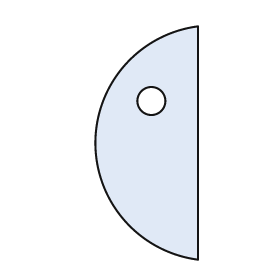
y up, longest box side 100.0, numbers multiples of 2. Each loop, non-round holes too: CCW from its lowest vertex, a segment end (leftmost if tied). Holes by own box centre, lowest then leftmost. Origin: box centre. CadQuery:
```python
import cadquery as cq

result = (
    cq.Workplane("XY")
    .moveTo(22.0, -50.0)
    .lineTo(22.0, 50.0)
    .threePointArc((-22.0, 0.0), (22.0, -50.0))
    .close()
    .moveTo(2.0, 18.0)
    .circle(6.0)
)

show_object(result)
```